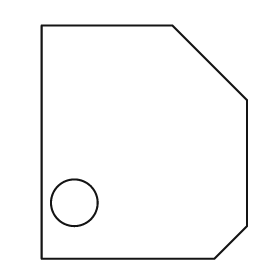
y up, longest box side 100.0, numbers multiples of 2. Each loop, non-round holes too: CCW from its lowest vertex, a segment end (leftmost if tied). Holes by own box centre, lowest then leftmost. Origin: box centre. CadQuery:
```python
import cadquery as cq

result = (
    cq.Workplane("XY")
    .moveTo(-44.0, -50.0)
    .lineTo(30.0, -50.0)
    .lineTo(44.0, -36.0)
    .lineTo(44.0, 18.0)
    .lineTo(12.0, 50.0)
    .lineTo(-44.0, 50.0)
    .close()
    .moveTo(-30.0, -26.0)
    .circle(10.0)
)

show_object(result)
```